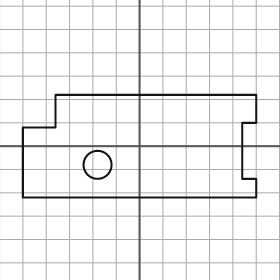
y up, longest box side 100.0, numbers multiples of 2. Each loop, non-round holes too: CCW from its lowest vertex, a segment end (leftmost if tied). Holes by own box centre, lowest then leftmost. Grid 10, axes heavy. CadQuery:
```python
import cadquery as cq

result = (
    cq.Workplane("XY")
    .moveTo(-50.0, -22.0)
    .lineTo(50.0, -22.0)
    .lineTo(50.0, -14.0)
    .lineTo(44.0, -14.0)
    .lineTo(44.0, 10.0)
    .lineTo(50.0, 10.0)
    .lineTo(50.0, 22.0)
    .lineTo(-36.0, 22.0)
    .lineTo(-36.0, 8.0)
    .lineTo(-50.0, 8.0)
    .close()
    .moveTo(-18.0, -8.0)
    .circle(6.0)
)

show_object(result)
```